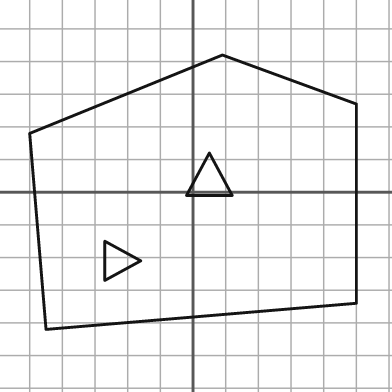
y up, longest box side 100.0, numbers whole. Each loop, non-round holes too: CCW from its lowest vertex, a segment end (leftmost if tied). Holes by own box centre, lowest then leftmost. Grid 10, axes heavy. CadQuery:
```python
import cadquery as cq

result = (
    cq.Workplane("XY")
    .moveTo(-45.0, -42.0)
    .lineTo(50.0, -34.0)
    .lineTo(50.0, 27.0)
    .lineTo(9.0, 42.0)
    .lineTo(-50.0, 18.0)
    .close()
    .moveTo(-27.0, -27.0)
    .lineTo(-16.0, -21.0)
    .lineTo(-27.0, -15.0)
    .close()
    .moveTo(-2.0, -1.0)
    .lineTo(12.0, -1.0)
    .lineTo(5.0, 12.0)
    .close()
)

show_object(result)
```